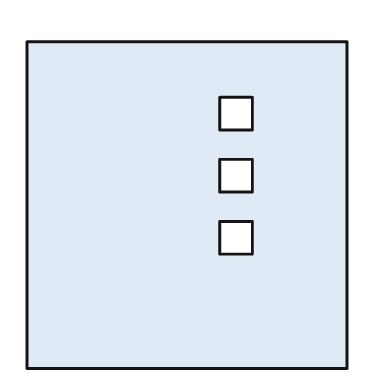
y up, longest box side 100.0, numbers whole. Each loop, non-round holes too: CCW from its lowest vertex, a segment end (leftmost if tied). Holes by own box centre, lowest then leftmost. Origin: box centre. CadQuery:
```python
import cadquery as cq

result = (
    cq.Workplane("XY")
    .moveTo(-49.0, -50.0)
    .lineTo(49.0, -50.0)
    .lineTo(49.0, 50.0)
    .lineTo(-49.0, 50.0)
    .close()
    .moveTo(10.0, -15.0)
    .lineTo(20.0, -15.0)
    .lineTo(20.0, -5.0)
    .lineTo(10.0, -5.0)
    .close()
    .moveTo(10.0, 4.0)
    .lineTo(20.0, 4.0)
    .lineTo(20.0, 14.0)
    .lineTo(10.0, 14.0)
    .close()
    .moveTo(10.0, 23.0)
    .lineTo(20.0, 23.0)
    .lineTo(20.0, 33.0)
    .lineTo(10.0, 33.0)
    .close()
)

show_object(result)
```